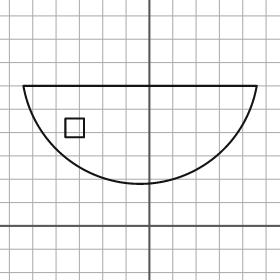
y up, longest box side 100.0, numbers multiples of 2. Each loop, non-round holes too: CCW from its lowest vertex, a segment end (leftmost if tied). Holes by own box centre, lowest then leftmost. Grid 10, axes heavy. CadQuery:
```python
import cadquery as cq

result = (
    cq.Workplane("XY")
    .moveTo(-54.0, 60.0)
    .threePointArc((-4.0, 18.0), (46.0, 60.0))
    .close()
    .moveTo(-36.0, 38.0)
    .lineTo(-28.0, 38.0)
    .lineTo(-28.0, 46.0)
    .lineTo(-36.0, 46.0)
    .close()
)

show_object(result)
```